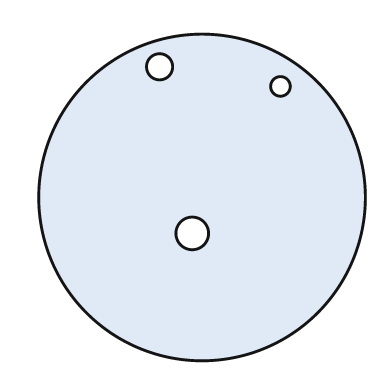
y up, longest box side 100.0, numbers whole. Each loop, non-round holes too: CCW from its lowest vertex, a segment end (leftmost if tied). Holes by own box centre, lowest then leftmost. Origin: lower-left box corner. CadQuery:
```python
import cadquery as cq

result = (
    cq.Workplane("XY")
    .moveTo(50.0, 50.0)
    .circle(50.0)
    .moveTo(47.0, 39.0)
    .circle(5.0)
    .moveTo(74.0, 84.0)
    .circle(3.0)
    .moveTo(37.0, 90.0)
    .circle(4.0)
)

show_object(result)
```